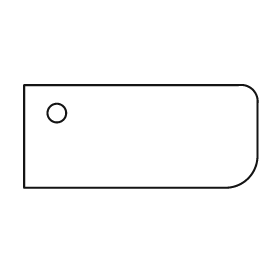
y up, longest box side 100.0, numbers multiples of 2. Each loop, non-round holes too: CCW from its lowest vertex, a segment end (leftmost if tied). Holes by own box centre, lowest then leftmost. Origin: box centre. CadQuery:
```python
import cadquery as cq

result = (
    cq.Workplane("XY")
    .moveTo(-50.0, -22.0)
    .lineTo(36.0, -22.0)
    .threePointArc((46.0, -18.0), (50.0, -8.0))
    .lineTo(50.0, 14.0)
    .threePointArc((48.0, 20.0), (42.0, 22.0))
    .lineTo(-50.0, 22.0)
    .close()
    .moveTo(-36.0, 10.0)
    .circle(4.0)
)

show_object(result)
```